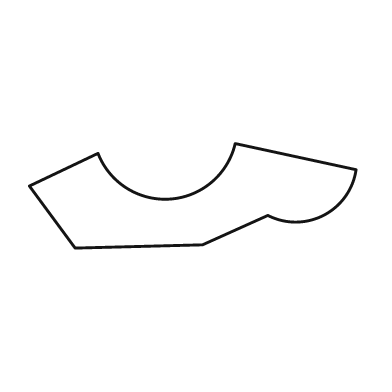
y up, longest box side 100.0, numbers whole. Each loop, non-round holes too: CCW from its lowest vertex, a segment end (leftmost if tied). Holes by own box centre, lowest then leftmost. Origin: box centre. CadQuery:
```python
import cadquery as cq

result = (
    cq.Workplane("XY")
    .moveTo(-36.0, -16.0)
    .lineTo(3.0, -15.0)
    .lineTo(23.0, -6.0)
    .threePointArc((40.0, -6.0), (50.0, 8.0))
    .lineTo(13.0, 16.0)
    .threePointArc((-7.0, -1.0), (-29.0, 13.0))
    .lineTo(-50.0, 3.0)
    .close()
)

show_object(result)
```